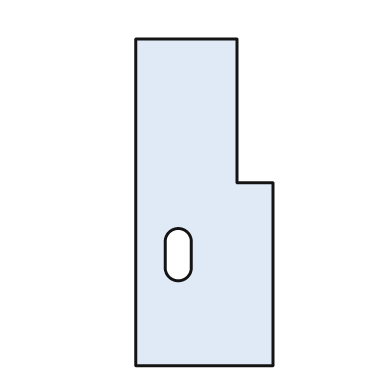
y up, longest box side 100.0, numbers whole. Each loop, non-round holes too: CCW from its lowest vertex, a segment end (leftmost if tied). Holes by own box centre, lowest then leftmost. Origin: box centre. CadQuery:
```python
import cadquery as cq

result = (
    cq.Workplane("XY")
    .moveTo(-21.0, -50.0)
    .lineTo(21.0, -50.0)
    .lineTo(21.0, 6.0)
    .lineTo(10.0, 6.0)
    .lineTo(10.0, 50.0)
    .lineTo(-21.0, 50.0)
    .close()
    .moveTo(-12.0, -20.0)
    .threePointArc((-8.0, -24.0), (-4.0, -20.0))
    .lineTo(-4.0, -12.0)
    .threePointArc((-8.0, -8.0), (-12.0, -12.0))
    .close()
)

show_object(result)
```